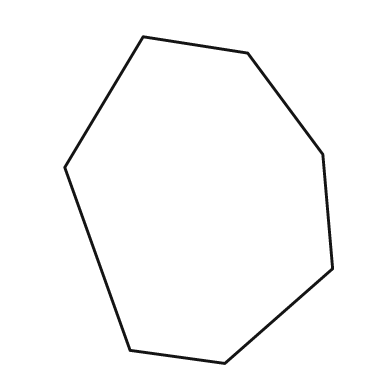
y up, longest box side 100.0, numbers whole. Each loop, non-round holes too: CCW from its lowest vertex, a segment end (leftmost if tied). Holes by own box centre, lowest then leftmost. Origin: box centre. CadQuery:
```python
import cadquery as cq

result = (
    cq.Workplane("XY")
    .moveTo(8.0, -50.0)
    .lineTo(41.0, -21.0)
    .lineTo(38.0, 14.0)
    .lineTo(15.0, 45.0)
    .lineTo(-17.0, 50.0)
    .lineTo(-41.0, 10.0)
    .lineTo(-21.0, -46.0)
    .close()
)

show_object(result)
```